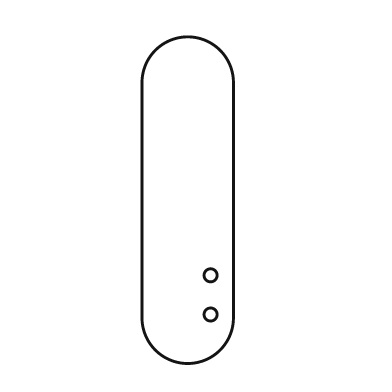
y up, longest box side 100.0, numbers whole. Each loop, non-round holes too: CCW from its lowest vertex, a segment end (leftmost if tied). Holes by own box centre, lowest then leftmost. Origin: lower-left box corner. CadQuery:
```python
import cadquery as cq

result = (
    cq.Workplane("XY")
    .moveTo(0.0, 14.0)
    .threePointArc((14.0, 0.0), (28.0, 14.0))
    .lineTo(28.0, 86.0)
    .threePointArc((14.0, 100.0), (0.0, 86.0))
    .close()
    .moveTo(21.0, 15.0)
    .circle(2.0)
    .moveTo(21.0, 27.0)
    .circle(2.0)
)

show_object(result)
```